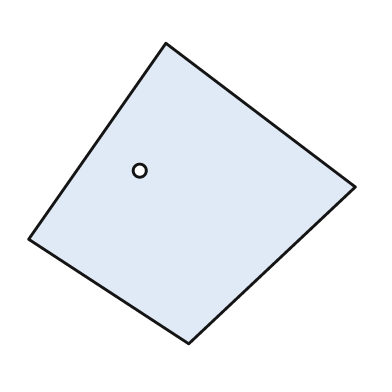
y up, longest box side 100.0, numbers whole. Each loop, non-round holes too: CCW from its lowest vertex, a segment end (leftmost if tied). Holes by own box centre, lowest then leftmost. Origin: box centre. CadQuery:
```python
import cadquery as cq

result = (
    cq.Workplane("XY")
    .moveTo(-1.0, -46.0)
    .lineTo(50.0, 2.0)
    .lineTo(-8.0, 46.0)
    .lineTo(-50.0, -14.0)
    .close()
    .moveTo(-16.0, 7.0)
    .circle(2.0)
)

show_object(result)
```